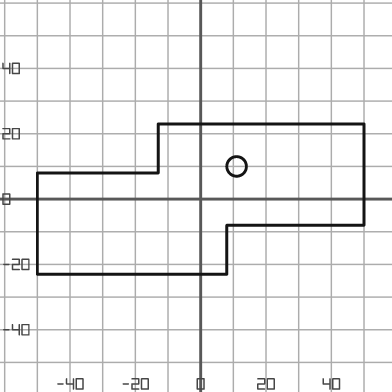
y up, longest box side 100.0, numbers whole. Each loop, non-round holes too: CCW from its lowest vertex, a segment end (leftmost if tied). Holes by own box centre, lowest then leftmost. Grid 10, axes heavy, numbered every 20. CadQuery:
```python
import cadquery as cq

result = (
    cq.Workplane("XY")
    .moveTo(-50.0, -23.0)
    .lineTo(8.0, -23.0)
    .lineTo(8.0, -8.0)
    .lineTo(50.0, -8.0)
    .lineTo(50.0, 23.0)
    .lineTo(-13.0, 23.0)
    .lineTo(-13.0, 8.0)
    .lineTo(-50.0, 8.0)
    .close()
    .moveTo(11.0, 10.0)
    .circle(3.0)
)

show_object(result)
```